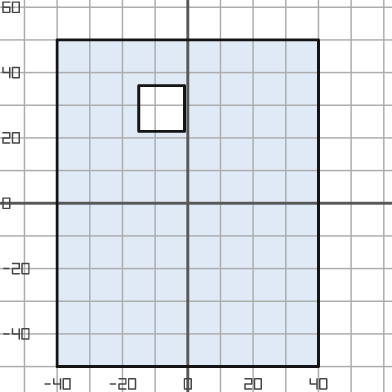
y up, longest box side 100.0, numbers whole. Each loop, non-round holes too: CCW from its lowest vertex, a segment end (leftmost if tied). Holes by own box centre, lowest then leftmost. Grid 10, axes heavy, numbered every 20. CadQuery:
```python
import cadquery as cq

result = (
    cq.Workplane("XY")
    .moveTo(-40.0, -50.0)
    .lineTo(40.0, -50.0)
    .lineTo(40.0, 50.0)
    .lineTo(-40.0, 50.0)
    .close()
    .moveTo(-15.0, 22.0)
    .lineTo(-1.0, 22.0)
    .lineTo(-1.0, 36.0)
    .lineTo(-15.0, 36.0)
    .close()
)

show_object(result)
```